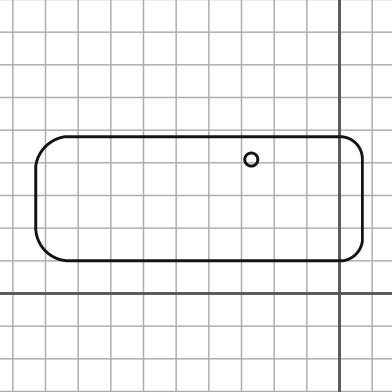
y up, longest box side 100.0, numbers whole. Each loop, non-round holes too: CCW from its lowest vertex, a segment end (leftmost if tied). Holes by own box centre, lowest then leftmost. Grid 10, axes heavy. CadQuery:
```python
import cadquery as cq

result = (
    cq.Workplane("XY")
    .moveTo(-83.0, 10.0)
    .lineTo(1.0, 10.0)
    .threePointArc((5.0, 12.0), (7.0, 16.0))
    .lineTo(7.0, 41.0)
    .threePointArc((5.0, 46.0), (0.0, 48.0))
    .lineTo(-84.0, 48.0)
    .threePointArc((-90.0, 45.0), (-93.0, 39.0))
    .lineTo(-93.0, 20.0)
    .threePointArc((-90.0, 13.0), (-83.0, 10.0))
    .close()
    .moveTo(-27.0, 41.0)
    .circle(2.0)
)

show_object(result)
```